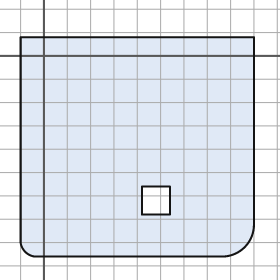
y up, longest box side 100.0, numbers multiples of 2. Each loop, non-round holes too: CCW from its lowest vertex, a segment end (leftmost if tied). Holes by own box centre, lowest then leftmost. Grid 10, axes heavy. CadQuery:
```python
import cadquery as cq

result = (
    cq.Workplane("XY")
    .moveTo(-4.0, -86.0)
    .lineTo(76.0, -86.0)
    .threePointArc((86.0, -82.0), (90.0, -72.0))
    .lineTo(90.0, 8.0)
    .lineTo(-10.0, 8.0)
    .lineTo(-10.0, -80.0)
    .threePointArc((-8.0, -84.0), (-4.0, -86.0))
    .close()
    .moveTo(42.0, -68.0)
    .lineTo(54.0, -68.0)
    .lineTo(54.0, -56.0)
    .lineTo(42.0, -56.0)
    .close()
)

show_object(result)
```